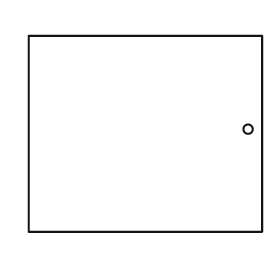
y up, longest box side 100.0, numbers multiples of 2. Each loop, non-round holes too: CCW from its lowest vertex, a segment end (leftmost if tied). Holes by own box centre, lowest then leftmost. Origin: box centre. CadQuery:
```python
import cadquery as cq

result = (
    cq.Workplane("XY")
    .moveTo(-50.0, -42.0)
    .lineTo(50.0, -42.0)
    .lineTo(50.0, 42.0)
    .lineTo(-50.0, 42.0)
    .close()
    .moveTo(44.0, 2.0)
    .circle(2.0)
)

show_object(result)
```